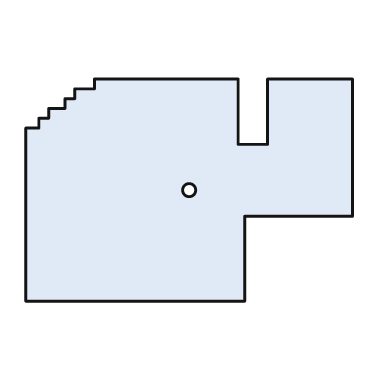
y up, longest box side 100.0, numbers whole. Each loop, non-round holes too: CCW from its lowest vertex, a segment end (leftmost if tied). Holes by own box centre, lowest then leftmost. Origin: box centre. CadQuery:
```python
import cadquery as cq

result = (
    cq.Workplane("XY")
    .moveTo(-50.0, -34.0)
    .lineTo(17.0, -34.0)
    .lineTo(17.0, -8.0)
    .lineTo(50.0, -8.0)
    .lineTo(50.0, 34.0)
    .lineTo(24.0, 34.0)
    .lineTo(24.0, 14.0)
    .lineTo(15.0, 14.0)
    .lineTo(15.0, 34.0)
    .lineTo(-29.0, 34.0)
    .lineTo(-29.0, 31.0)
    .lineTo(-35.0, 31.0)
    .lineTo(-35.0, 28.0)
    .lineTo(-38.0, 28.0)
    .lineTo(-38.0, 25.0)
    .lineTo(-43.0, 25.0)
    .lineTo(-43.0, 22.0)
    .lineTo(-46.0, 22.0)
    .lineTo(-46.0, 19.0)
    .lineTo(-50.0, 19.0)
    .close()
    .moveTo(0.0, 0.0)
    .circle(2.0)
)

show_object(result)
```